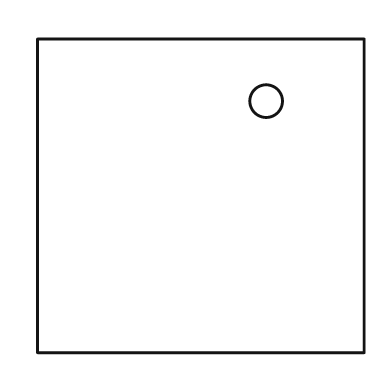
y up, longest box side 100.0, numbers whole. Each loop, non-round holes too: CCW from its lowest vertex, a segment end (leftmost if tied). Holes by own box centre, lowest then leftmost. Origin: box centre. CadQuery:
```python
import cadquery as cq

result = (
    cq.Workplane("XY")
    .moveTo(-50.0, -48.0)
    .lineTo(50.0, -48.0)
    .lineTo(50.0, 48.0)
    .lineTo(-50.0, 48.0)
    .close()
    .moveTo(20.0, 29.0)
    .circle(5.0)
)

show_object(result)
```